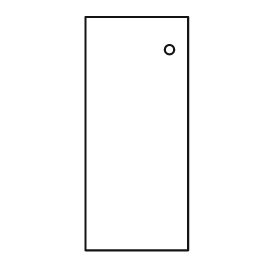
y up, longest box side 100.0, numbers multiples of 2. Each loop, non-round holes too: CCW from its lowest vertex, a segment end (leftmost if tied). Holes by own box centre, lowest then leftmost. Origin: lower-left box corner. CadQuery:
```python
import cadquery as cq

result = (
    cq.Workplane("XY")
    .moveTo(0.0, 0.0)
    .lineTo(44.0, 0.0)
    .lineTo(44.0, 100.0)
    .lineTo(0.0, 100.0)
    .close()
    .moveTo(36.0, 86.0)
    .circle(2.0)
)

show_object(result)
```